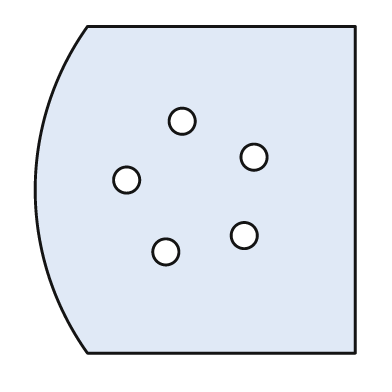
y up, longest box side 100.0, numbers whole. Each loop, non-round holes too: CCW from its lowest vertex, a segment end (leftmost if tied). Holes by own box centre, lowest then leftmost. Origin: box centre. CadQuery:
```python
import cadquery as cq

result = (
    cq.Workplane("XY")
    .moveTo(-33.0, -50.0)
    .lineTo(49.0, -50.0)
    .lineTo(49.0, 50.0)
    .lineTo(-33.0, 50.0)
    .threePointArc((-49.0, 0.0), (-33.0, -50.0))
    .close()
    .moveTo(-9.0, -19.0)
    .circle(4.0)
    .moveTo(15.0, -14.0)
    .circle(4.0)
    .moveTo(-21.0, 3.0)
    .circle(4.0)
    .moveTo(18.0, 10.0)
    .circle(4.0)
    .moveTo(-4.0, 21.0)
    .circle(4.0)
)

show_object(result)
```